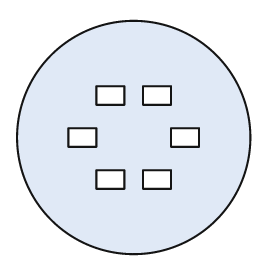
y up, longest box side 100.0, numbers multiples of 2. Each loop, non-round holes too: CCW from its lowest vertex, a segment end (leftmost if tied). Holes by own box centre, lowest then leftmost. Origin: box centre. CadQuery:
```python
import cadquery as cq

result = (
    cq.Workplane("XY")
    .moveTo(0.0, 0.0)
    .circle(50.0)
    .moveTo(-16.0, -22.0)
    .lineTo(-4.0, -22.0)
    .lineTo(-4.0, -14.0)
    .lineTo(-16.0, -14.0)
    .close()
    .moveTo(4.0, -22.0)
    .lineTo(16.0, -22.0)
    .lineTo(16.0, -14.0)
    .lineTo(4.0, -14.0)
    .close()
    .moveTo(-28.0, -4.0)
    .lineTo(-16.0, -4.0)
    .lineTo(-16.0, 4.0)
    .lineTo(-28.0, 4.0)
    .close()
    .moveTo(16.0, -4.0)
    .lineTo(28.0, -4.0)
    .lineTo(28.0, 4.0)
    .lineTo(16.0, 4.0)
    .close()
    .moveTo(-16.0, 14.0)
    .lineTo(-4.0, 14.0)
    .lineTo(-4.0, 22.0)
    .lineTo(-16.0, 22.0)
    .close()
    .moveTo(4.0, 14.0)
    .lineTo(16.0, 14.0)
    .lineTo(16.0, 22.0)
    .lineTo(4.0, 22.0)
    .close()
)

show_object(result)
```